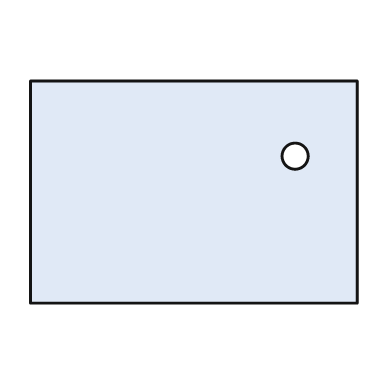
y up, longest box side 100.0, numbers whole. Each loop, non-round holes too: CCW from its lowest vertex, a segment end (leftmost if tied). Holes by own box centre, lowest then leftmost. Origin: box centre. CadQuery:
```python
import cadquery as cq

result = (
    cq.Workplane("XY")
    .moveTo(-50.0, -34.0)
    .lineTo(50.0, -34.0)
    .lineTo(50.0, 34.0)
    .lineTo(-50.0, 34.0)
    .close()
    .moveTo(31.0, 11.0)
    .circle(4.0)
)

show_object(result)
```